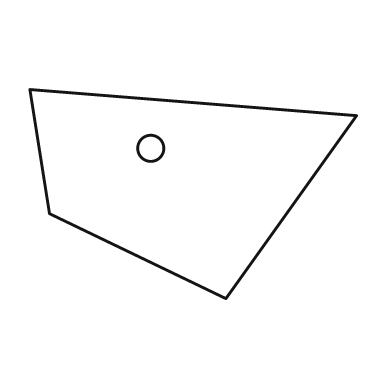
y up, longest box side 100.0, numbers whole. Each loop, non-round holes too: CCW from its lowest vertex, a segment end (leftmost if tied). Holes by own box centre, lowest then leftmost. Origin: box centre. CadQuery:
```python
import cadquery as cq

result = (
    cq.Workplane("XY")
    .moveTo(10.0, -32.0)
    .lineTo(50.0, 24.0)
    .lineTo(-50.0, 32.0)
    .lineTo(-44.0, -6.0)
    .close()
    .moveTo(-13.0, 14.0)
    .circle(4.0)
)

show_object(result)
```